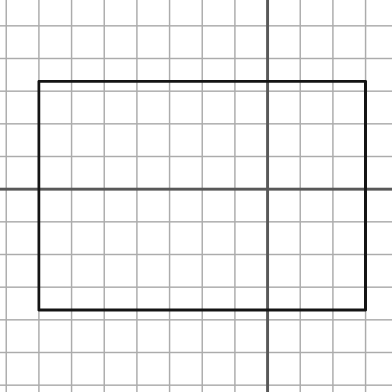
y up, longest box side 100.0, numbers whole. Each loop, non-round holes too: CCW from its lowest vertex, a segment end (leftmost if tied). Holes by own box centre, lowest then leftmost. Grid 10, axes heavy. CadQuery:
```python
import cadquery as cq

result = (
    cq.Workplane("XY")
    .moveTo(-70.0, -37.0)
    .lineTo(30.0, -37.0)
    .lineTo(30.0, 33.0)
    .lineTo(-70.0, 33.0)
    .close()
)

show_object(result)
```